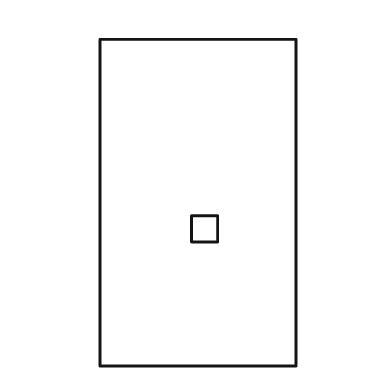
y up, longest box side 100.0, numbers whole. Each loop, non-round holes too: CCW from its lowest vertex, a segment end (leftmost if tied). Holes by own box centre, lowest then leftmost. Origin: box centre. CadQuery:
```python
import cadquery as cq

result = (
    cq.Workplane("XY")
    .moveTo(-30.0, -50.0)
    .lineTo(30.0, -50.0)
    .lineTo(30.0, 50.0)
    .lineTo(-30.0, 50.0)
    .close()
    .moveTo(-2.0, -12.0)
    .lineTo(6.0, -12.0)
    .lineTo(6.0, -4.0)
    .lineTo(-2.0, -4.0)
    .close()
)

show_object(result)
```